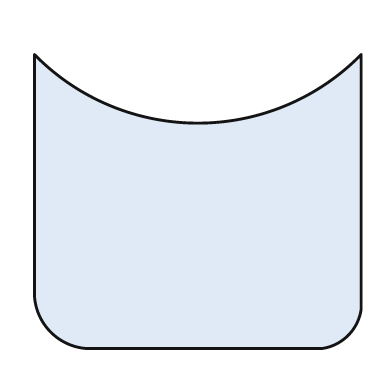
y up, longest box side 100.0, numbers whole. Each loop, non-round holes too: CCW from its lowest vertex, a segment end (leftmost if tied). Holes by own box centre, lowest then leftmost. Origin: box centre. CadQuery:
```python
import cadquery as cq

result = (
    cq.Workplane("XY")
    .moveTo(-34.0, -45.0)
    .lineTo(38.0, -45.0)
    .threePointArc((46.0, -41.0), (50.0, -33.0))
    .lineTo(50.0, 45.0)
    .threePointArc((0.0, 24.0), (-50.0, 45.0))
    .lineTo(-50.0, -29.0)
    .threePointArc((-45.0, -40.0), (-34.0, -45.0))
    .close()
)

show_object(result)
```